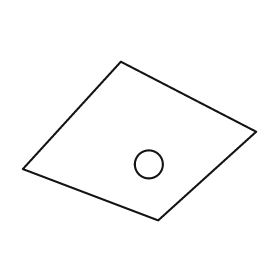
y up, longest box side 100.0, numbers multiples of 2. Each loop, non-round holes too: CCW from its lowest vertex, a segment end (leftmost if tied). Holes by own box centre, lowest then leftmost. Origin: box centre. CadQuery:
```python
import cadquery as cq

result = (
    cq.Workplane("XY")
    .moveTo(8.0, -34.0)
    .lineTo(50.0, 4.0)
    .lineTo(-8.0, 34.0)
    .lineTo(-50.0, -12.0)
    .close()
    .moveTo(4.0, -10.0)
    .circle(6.0)
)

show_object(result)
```